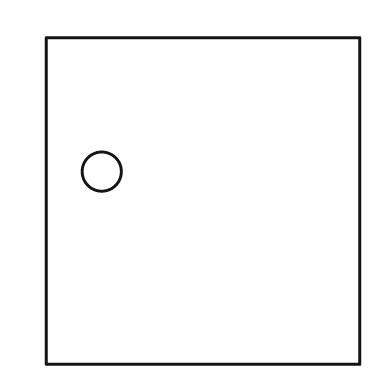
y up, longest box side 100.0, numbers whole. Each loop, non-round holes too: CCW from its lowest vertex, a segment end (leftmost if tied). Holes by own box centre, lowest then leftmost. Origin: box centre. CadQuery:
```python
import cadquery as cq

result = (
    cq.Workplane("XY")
    .moveTo(-48.0, -50.0)
    .lineTo(48.0, -50.0)
    .lineTo(48.0, 50.0)
    .lineTo(-48.0, 50.0)
    .close()
    .moveTo(-31.0, 9.0)
    .circle(6.0)
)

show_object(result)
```